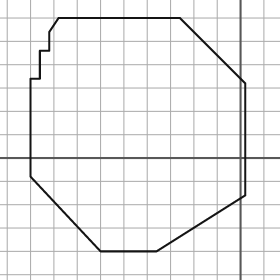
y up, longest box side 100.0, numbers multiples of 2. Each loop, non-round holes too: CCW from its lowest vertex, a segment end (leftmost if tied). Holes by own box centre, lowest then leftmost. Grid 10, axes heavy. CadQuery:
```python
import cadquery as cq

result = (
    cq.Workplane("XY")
    .moveTo(-60.0, -40.0)
    .lineTo(-36.0, -40.0)
    .lineTo(2.0, -16.0)
    .lineTo(2.0, 32.0)
    .lineTo(-26.0, 60.0)
    .lineTo(-78.0, 60.0)
    .lineTo(-82.0, 54.0)
    .lineTo(-82.0, 46.0)
    .lineTo(-86.0, 46.0)
    .lineTo(-86.0, 34.0)
    .lineTo(-90.0, 34.0)
    .lineTo(-90.0, -8.0)
    .close()
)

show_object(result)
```